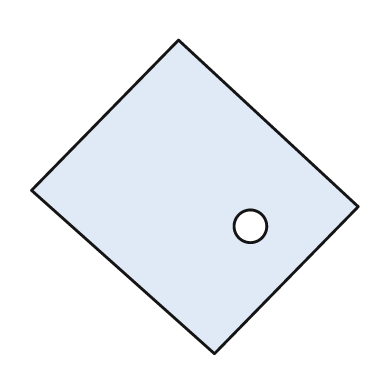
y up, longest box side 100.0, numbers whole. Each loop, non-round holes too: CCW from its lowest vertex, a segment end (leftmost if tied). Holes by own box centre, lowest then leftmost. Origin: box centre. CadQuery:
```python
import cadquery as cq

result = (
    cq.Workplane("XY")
    .moveTo(6.0, -48.0)
    .lineTo(50.0, -3.0)
    .lineTo(-5.0, 48.0)
    .lineTo(-50.0, 2.0)
    .close()
    .moveTo(17.0, -9.0)
    .circle(5.0)
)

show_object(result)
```